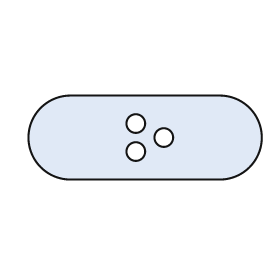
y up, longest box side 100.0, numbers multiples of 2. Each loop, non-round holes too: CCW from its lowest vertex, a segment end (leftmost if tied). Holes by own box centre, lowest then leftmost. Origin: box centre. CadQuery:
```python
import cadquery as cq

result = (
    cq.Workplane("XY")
    .moveTo(-32.0, -18.0)
    .lineTo(32.0, -18.0)
    .threePointArc((50.0, 0.0), (32.0, 18.0))
    .lineTo(-32.0, 18.0)
    .threePointArc((-50.0, 0.0), (-32.0, -18.0))
    .close()
    .moveTo(-4.0, -6.0)
    .circle(4.0)
    .moveTo(8.0, 0.0)
    .circle(4.0)
    .moveTo(-4.0, 6.0)
    .circle(4.0)
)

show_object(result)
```